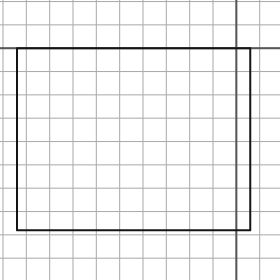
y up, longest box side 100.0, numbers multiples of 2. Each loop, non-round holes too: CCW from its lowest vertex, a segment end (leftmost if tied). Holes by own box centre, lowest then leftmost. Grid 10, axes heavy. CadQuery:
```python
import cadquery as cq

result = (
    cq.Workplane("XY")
    .moveTo(-94.0, -78.0)
    .lineTo(6.0, -78.0)
    .lineTo(6.0, 0.0)
    .lineTo(-94.0, 0.0)
    .close()
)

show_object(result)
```